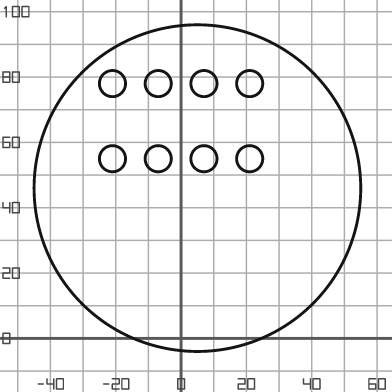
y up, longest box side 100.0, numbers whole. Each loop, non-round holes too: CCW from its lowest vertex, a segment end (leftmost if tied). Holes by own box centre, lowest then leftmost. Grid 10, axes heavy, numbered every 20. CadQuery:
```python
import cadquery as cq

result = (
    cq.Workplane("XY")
    .moveTo(5.0, 46.0)
    .circle(50.0)
    .moveTo(-21.0, 55.0)
    .circle(4.0)
    .moveTo(-7.0, 55.0)
    .circle(4.0)
    .moveTo(7.0, 55.0)
    .circle(4.0)
    .moveTo(21.0, 55.0)
    .circle(4.0)
    .moveTo(-21.0, 78.0)
    .circle(4.0)
    .moveTo(-7.0, 78.0)
    .circle(4.0)
    .moveTo(7.0, 78.0)
    .circle(4.0)
    .moveTo(21.0, 78.0)
    .circle(4.0)
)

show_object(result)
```